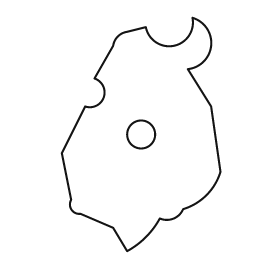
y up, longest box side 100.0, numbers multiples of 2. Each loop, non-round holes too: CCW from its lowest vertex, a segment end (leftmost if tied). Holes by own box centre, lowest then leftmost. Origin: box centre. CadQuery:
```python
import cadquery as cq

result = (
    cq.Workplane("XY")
    .moveTo(-6.0, -50.0)
    .threePointArc((2.0, -44.0), (8.0, -36.0))
    .threePointArc((14.0, -36.0), (18.0, -32.0))
    .threePointArc((28.0, -26.0), (34.0, -16.0))
    .lineTo(30.0, 12.0)
    .lineTo(20.0, 28.0)
    .threePointArc((30.0, 38.0), (22.0, 50.0))
    .threePointArc((14.0, 38.0), (2.0, 46.0))
    .lineTo(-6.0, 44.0)
    .threePointArc((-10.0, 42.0), (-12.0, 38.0))
    .lineTo(-20.0, 24.0)
    .threePointArc((-16.0, 16.0), (-24.0, 12.0))
    .lineTo(-34.0, -8.0)
    .lineTo(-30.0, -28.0)
    .threePointArc((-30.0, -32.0), (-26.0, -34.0))
    .lineTo(-12.0, -40.0)
    .close()
    .moveTo(0.0, 0.0)
    .circle(6.0)
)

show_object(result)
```